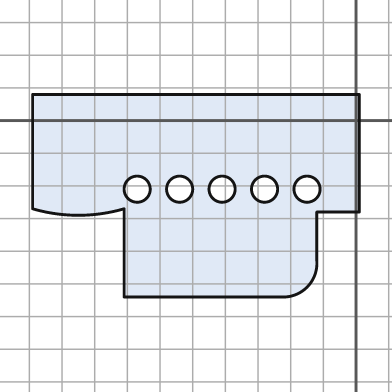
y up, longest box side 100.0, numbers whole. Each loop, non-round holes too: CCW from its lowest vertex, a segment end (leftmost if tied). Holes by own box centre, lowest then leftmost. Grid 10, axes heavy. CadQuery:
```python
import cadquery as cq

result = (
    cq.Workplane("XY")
    .moveTo(-71.0, -54.0)
    .lineTo(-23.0, -54.0)
    .threePointArc((-15.0, -51.0), (-12.0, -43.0))
    .lineTo(-12.0, -28.0)
    .lineTo(1.0, -28.0)
    .lineTo(1.0, 8.0)
    .lineTo(-99.0, 8.0)
    .lineTo(-99.0, -27.0)
    .threePointArc((-85.0, -29.0), (-71.0, -27.0))
    .close()
    .moveTo(-67.0, -21.0)
    .circle(4.0)
    .moveTo(-54.0, -21.0)
    .circle(4.0)
    .moveTo(-41.0, -21.0)
    .circle(4.0)
    .moveTo(-28.0, -21.0)
    .circle(4.0)
    .moveTo(-15.0, -21.0)
    .circle(4.0)
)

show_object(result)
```